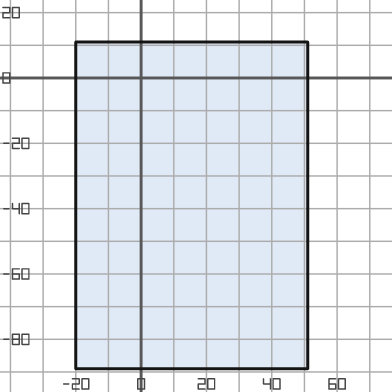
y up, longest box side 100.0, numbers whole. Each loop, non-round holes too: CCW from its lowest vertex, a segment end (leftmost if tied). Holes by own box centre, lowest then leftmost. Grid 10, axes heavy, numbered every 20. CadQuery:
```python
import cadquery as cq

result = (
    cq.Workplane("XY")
    .moveTo(-20.0, -89.0)
    .lineTo(51.0, -89.0)
    .lineTo(51.0, 11.0)
    .lineTo(-20.0, 11.0)
    .close()
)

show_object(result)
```